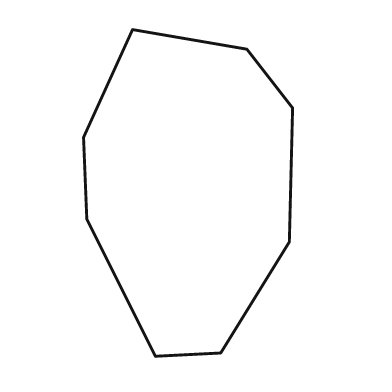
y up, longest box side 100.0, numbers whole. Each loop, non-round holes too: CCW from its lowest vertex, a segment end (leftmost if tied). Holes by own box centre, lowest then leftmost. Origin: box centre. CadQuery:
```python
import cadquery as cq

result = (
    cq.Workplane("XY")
    .moveTo(-10.0, -50.0)
    .lineTo(10.0, -49.0)
    .lineTo(31.0, -15.0)
    .lineTo(32.0, 26.0)
    .lineTo(18.0, 44.0)
    .lineTo(-17.0, 50.0)
    .lineTo(-32.0, 17.0)
    .lineTo(-31.0, -8.0)
    .close()
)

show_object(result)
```